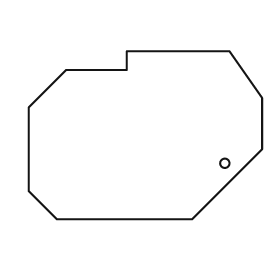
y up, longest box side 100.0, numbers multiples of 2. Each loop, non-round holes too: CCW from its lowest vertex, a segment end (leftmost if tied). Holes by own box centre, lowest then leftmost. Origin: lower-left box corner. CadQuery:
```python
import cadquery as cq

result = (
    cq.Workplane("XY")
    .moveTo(12.0, 0.0)
    .lineTo(70.0, 0.0)
    .lineTo(100.0, 30.0)
    .lineTo(100.0, 52.0)
    .lineTo(86.0, 72.0)
    .lineTo(42.0, 72.0)
    .lineTo(42.0, 64.0)
    .lineTo(16.0, 64.0)
    .lineTo(0.0, 48.0)
    .lineTo(0.0, 12.0)
    .close()
    .moveTo(84.0, 24.0)
    .circle(2.0)
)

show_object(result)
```